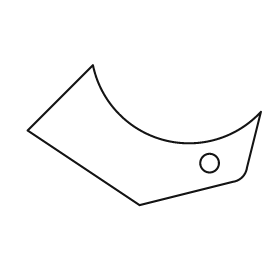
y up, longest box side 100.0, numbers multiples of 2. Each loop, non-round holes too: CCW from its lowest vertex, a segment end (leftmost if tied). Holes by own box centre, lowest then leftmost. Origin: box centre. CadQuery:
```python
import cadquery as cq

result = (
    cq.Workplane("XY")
    .moveTo(-2.0, -30.0)
    .lineTo(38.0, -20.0)
    .threePointArc((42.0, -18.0), (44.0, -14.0))
    .lineTo(50.0, 10.0)
    .threePointArc((8.0, -2.0), (-22.0, 30.0))
    .lineTo(-50.0, 2.0)
    .close()
    .moveTo(28.0, -12.0)
    .circle(4.0)
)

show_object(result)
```